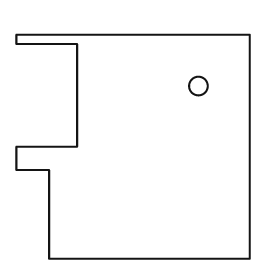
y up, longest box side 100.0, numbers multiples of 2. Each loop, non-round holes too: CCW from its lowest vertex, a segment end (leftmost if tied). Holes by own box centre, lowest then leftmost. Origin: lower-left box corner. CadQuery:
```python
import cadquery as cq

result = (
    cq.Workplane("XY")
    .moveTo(14.0, 0.0)
    .lineTo(100.0, 0.0)
    .lineTo(100.0, 96.0)
    .lineTo(0.0, 96.0)
    .lineTo(0.0, 92.0)
    .lineTo(26.0, 92.0)
    .lineTo(26.0, 48.0)
    .lineTo(0.0, 48.0)
    .lineTo(0.0, 38.0)
    .lineTo(14.0, 38.0)
    .close()
    .moveTo(78.0, 74.0)
    .circle(4.0)
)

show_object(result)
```